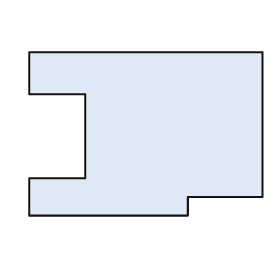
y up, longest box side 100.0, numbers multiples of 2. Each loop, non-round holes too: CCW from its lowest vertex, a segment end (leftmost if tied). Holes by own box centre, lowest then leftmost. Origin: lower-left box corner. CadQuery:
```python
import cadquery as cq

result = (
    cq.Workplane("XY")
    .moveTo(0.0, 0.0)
    .lineTo(68.0, 0.0)
    .lineTo(68.0, 8.0)
    .lineTo(100.0, 8.0)
    .lineTo(100.0, 70.0)
    .lineTo(0.0, 70.0)
    .lineTo(0.0, 52.0)
    .lineTo(24.0, 52.0)
    .lineTo(24.0, 16.0)
    .lineTo(0.0, 16.0)
    .close()
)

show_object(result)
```